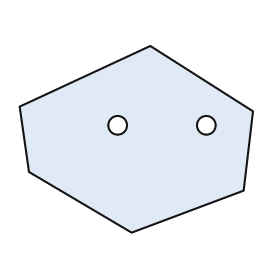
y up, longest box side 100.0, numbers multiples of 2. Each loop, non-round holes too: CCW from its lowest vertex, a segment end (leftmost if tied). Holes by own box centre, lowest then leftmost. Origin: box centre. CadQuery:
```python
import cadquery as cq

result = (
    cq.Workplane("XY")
    .moveTo(-2.0, -40.0)
    .lineTo(46.0, -22.0)
    .lineTo(50.0, 12.0)
    .lineTo(6.0, 40.0)
    .lineTo(-50.0, 14.0)
    .lineTo(-46.0, -14.0)
    .close()
    .moveTo(-8.0, 6.0)
    .circle(4.0)
    .moveTo(30.0, 6.0)
    .circle(4.0)
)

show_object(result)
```